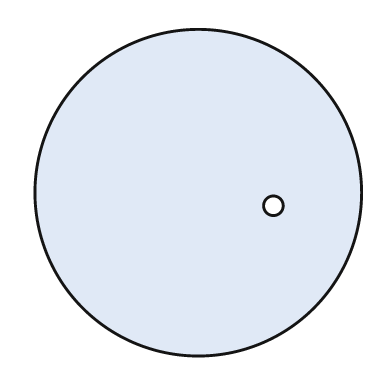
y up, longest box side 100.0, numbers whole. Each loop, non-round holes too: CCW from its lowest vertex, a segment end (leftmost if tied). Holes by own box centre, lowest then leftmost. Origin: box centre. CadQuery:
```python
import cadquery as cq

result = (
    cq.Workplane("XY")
    .moveTo(0.0, 0.0)
    .circle(50.0)
    .moveTo(23.0, -4.0)
    .circle(3.0)
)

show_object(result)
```